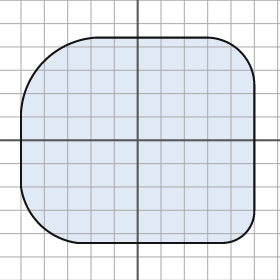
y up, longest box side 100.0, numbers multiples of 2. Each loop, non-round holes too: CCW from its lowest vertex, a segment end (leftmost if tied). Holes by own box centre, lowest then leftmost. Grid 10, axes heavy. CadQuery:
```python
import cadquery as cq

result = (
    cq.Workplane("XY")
    .moveTo(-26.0, -44.0)
    .lineTo(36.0, -44.0)
    .threePointArc((46.0, -40.0), (50.0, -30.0))
    .lineTo(50.0, 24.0)
    .threePointArc((44.0, 38.0), (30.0, 44.0))
    .lineTo(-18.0, 44.0)
    .threePointArc((-40.0, 34.0), (-50.0, 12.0))
    .lineTo(-50.0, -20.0)
    .threePointArc((-42.0, -36.0), (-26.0, -44.0))
    .close()
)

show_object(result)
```